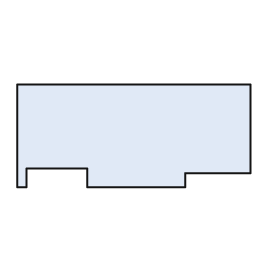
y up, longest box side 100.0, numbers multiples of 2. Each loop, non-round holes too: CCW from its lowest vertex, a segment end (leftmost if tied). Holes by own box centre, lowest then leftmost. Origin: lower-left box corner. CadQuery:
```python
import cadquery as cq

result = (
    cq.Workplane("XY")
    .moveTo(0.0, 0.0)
    .lineTo(4.0, 0.0)
    .lineTo(4.0, 8.0)
    .lineTo(30.0, 8.0)
    .lineTo(30.0, 0.0)
    .lineTo(72.0, 0.0)
    .lineTo(72.0, 6.0)
    .lineTo(100.0, 6.0)
    .lineTo(100.0, 44.0)
    .lineTo(0.0, 44.0)
    .close()
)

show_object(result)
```